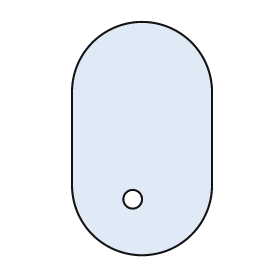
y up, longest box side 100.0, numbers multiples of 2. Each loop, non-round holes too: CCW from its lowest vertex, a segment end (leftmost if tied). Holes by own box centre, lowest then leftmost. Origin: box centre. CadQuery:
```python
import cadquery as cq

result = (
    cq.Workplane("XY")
    .moveTo(-30.0, -20.0)
    .threePointArc((0.0, -50.0), (30.0, -20.0))
    .lineTo(30.0, 20.0)
    .threePointArc((0.0, 50.0), (-30.0, 20.0))
    .close()
    .moveTo(-4.0, -26.0)
    .circle(4.0)
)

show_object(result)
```